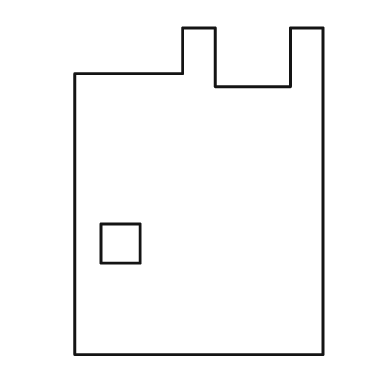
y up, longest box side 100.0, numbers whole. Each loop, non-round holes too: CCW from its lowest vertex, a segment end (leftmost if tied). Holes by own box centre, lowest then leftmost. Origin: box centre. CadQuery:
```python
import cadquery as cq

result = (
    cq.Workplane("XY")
    .moveTo(-38.0, -50.0)
    .lineTo(38.0, -50.0)
    .lineTo(38.0, 50.0)
    .lineTo(28.0, 50.0)
    .lineTo(28.0, 32.0)
    .lineTo(5.0, 32.0)
    .lineTo(5.0, 50.0)
    .lineTo(-5.0, 50.0)
    .lineTo(-5.0, 36.0)
    .lineTo(-38.0, 36.0)
    .close()
    .moveTo(-30.0, -22.0)
    .lineTo(-18.0, -22.0)
    .lineTo(-18.0, -10.0)
    .lineTo(-30.0, -10.0)
    .close()
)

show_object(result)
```